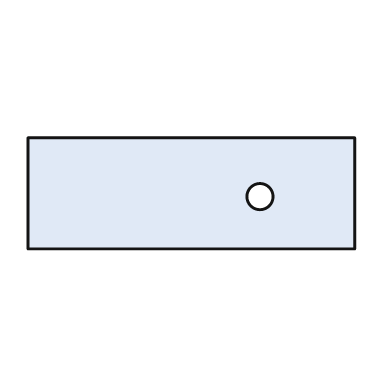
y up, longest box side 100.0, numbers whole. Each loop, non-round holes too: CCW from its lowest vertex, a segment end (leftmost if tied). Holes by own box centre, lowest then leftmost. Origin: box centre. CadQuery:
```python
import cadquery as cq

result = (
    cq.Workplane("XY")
    .moveTo(-50.0, -17.0)
    .lineTo(50.0, -17.0)
    .lineTo(50.0, 17.0)
    .lineTo(-50.0, 17.0)
    .close()
    .moveTo(21.0, -1.0)
    .circle(4.0)
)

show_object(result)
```